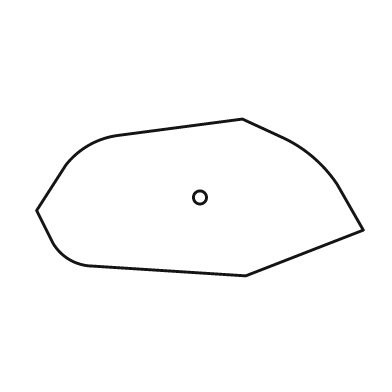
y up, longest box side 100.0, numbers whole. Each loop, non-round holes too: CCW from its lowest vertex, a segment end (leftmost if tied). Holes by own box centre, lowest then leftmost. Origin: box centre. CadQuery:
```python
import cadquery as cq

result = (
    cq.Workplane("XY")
    .moveTo(14.0, -24.0)
    .lineTo(50.0, -10.0)
    .lineTo(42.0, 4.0)
    .threePointArc((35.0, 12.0), (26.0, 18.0))
    .lineTo(13.0, 24.0)
    .lineTo(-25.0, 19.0)
    .threePointArc((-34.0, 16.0), (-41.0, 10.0))
    .lineTo(-50.0, -4.0)
    .lineTo(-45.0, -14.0)
    .threePointArc((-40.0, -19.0), (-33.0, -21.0))
    .close()
    .moveTo(0.0, 0.0)
    .circle(2.0)
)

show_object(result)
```